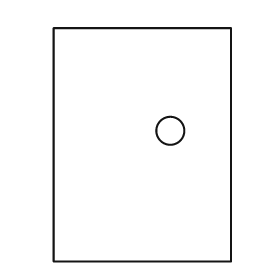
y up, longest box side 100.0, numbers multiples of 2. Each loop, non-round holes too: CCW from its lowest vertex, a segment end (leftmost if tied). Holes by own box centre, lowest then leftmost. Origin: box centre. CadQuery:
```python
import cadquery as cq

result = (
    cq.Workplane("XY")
    .moveTo(-38.0, -50.0)
    .lineTo(38.0, -50.0)
    .lineTo(38.0, 50.0)
    .lineTo(-38.0, 50.0)
    .close()
    .moveTo(12.0, 6.0)
    .circle(6.0)
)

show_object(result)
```